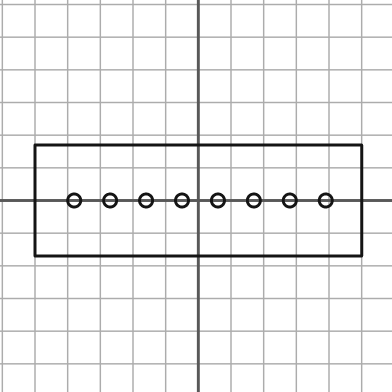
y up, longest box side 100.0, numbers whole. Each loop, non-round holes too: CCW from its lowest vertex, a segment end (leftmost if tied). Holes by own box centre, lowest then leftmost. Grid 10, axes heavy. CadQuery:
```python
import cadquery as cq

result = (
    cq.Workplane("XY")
    .moveTo(-50.0, -17.0)
    .lineTo(50.0, -17.0)
    .lineTo(50.0, 17.0)
    .lineTo(-50.0, 17.0)
    .close()
    .moveTo(-38.0, 0.0)
    .circle(2.0)
    .moveTo(-27.0, 0.0)
    .circle(2.0)
    .moveTo(-16.0, 0.0)
    .circle(2.0)
    .moveTo(-5.0, 0.0)
    .circle(2.0)
    .moveTo(6.0, 0.0)
    .circle(2.0)
    .moveTo(17.0, 0.0)
    .circle(2.0)
    .moveTo(28.0, 0.0)
    .circle(2.0)
    .moveTo(39.0, 0.0)
    .circle(2.0)
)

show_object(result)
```